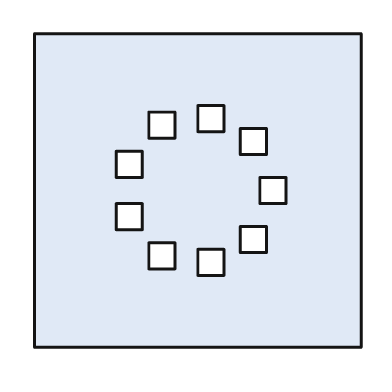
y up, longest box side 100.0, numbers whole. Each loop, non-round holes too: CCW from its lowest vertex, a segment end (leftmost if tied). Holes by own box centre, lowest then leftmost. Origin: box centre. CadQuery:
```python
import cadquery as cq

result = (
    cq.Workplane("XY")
    .moveTo(-50.0, -48.0)
    .lineTo(50.0, -48.0)
    .lineTo(50.0, 48.0)
    .lineTo(-50.0, 48.0)
    .close()
    .moveTo(0.0, -26.0)
    .lineTo(8.0, -26.0)
    .lineTo(8.0, -18.0)
    .lineTo(0.0, -18.0)
    .close()
    .moveTo(-15.0, -24.0)
    .lineTo(-7.0, -24.0)
    .lineTo(-7.0, -16.0)
    .lineTo(-15.0, -16.0)
    .close()
    .moveTo(13.0, -19.0)
    .lineTo(21.0, -19.0)
    .lineTo(21.0, -11.0)
    .lineTo(13.0, -11.0)
    .close()
    .moveTo(-25.0, -12.0)
    .lineTo(-17.0, -12.0)
    .lineTo(-17.0, -4.0)
    .lineTo(-25.0, -4.0)
    .close()
    .moveTo(19.0, -4.0)
    .lineTo(27.0, -4.0)
    .lineTo(27.0, 4.0)
    .lineTo(19.0, 4.0)
    .close()
    .moveTo(-25.0, 4.0)
    .lineTo(-17.0, 4.0)
    .lineTo(-17.0, 12.0)
    .lineTo(-25.0, 12.0)
    .close()
    .moveTo(13.0, 11.0)
    .lineTo(21.0, 11.0)
    .lineTo(21.0, 19.0)
    .lineTo(13.0, 19.0)
    .close()
    .moveTo(-15.0, 16.0)
    .lineTo(-7.0, 16.0)
    .lineTo(-7.0, 24.0)
    .lineTo(-15.0, 24.0)
    .close()
    .moveTo(0.0, 18.0)
    .lineTo(8.0, 18.0)
    .lineTo(8.0, 26.0)
    .lineTo(0.0, 26.0)
    .close()
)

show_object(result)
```